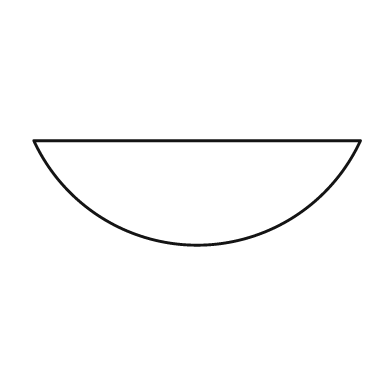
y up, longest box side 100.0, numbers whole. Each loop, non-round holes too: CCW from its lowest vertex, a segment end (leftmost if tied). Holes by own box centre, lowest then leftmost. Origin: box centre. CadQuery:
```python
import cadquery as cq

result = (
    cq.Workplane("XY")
    .moveTo(-50.0, 16.0)
    .threePointArc((0.0, -16.0), (50.0, 16.0))
    .close()
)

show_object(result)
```